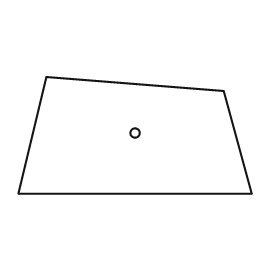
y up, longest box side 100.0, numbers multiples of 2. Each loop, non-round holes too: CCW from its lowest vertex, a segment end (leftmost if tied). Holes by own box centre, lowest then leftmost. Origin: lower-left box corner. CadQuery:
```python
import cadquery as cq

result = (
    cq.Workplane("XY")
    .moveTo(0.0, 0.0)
    .lineTo(100.0, 0.0)
    .lineTo(88.0, 44.0)
    .lineTo(12.0, 50.0)
    .close()
    .moveTo(50.0, 26.0)
    .circle(2.0)
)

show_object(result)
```